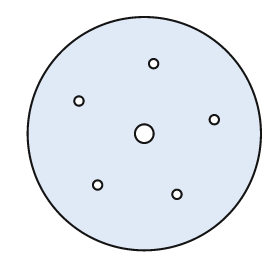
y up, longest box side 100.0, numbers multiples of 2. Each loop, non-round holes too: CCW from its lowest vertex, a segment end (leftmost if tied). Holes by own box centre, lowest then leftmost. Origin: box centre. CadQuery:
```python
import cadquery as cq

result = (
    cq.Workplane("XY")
    .moveTo(0.0, 0.0)
    .circle(50.0)
    .moveTo(14.0, -26.0)
    .circle(2.0)
    .moveTo(-20.0, -22.0)
    .circle(2.0)
    .moveTo(0.0, 0.0)
    .circle(4.0)
    .moveTo(30.0, 6.0)
    .circle(2.0)
    .moveTo(-28.0, 14.0)
    .circle(2.0)
    .moveTo(4.0, 30.0)
    .circle(2.0)
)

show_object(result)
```